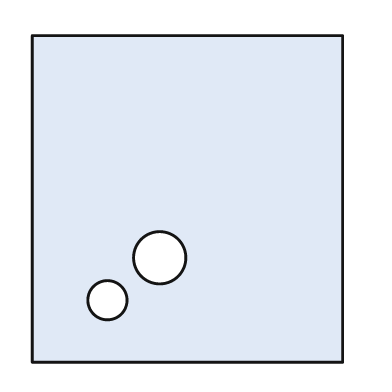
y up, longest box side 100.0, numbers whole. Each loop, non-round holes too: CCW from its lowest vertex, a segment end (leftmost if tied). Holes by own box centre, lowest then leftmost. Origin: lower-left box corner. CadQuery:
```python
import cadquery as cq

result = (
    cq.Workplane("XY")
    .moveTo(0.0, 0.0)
    .lineTo(95.0, 0.0)
    .lineTo(95.0, 100.0)
    .lineTo(0.0, 100.0)
    .close()
    .moveTo(23.0, 19.0)
    .circle(6.0)
    .moveTo(39.0, 32.0)
    .circle(8.0)
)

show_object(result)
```